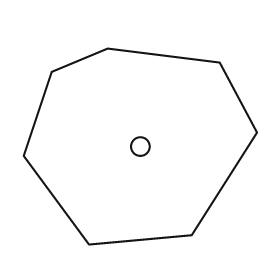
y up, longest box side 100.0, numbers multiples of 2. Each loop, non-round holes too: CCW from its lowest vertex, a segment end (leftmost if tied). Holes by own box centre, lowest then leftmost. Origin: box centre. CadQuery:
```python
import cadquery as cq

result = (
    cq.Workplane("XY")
    .moveTo(-22.0, -42.0)
    .lineTo(22.0, -38.0)
    .lineTo(50.0, 6.0)
    .lineTo(34.0, 36.0)
    .lineTo(-14.0, 42.0)
    .lineTo(-38.0, 32.0)
    .lineTo(-50.0, -4.0)
    .close()
    .moveTo(0.0, 0.0)
    .circle(4.0)
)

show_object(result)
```